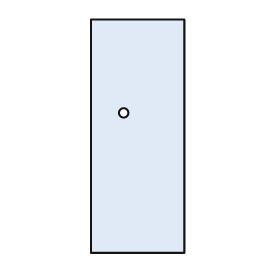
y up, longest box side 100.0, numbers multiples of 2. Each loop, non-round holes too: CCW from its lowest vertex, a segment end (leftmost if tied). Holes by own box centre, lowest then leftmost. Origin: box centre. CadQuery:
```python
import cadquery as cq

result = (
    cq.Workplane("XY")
    .moveTo(-20.0, -50.0)
    .lineTo(20.0, -50.0)
    .lineTo(20.0, 50.0)
    .lineTo(-20.0, 50.0)
    .close()
    .moveTo(-6.0, 10.0)
    .circle(2.0)
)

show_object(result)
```